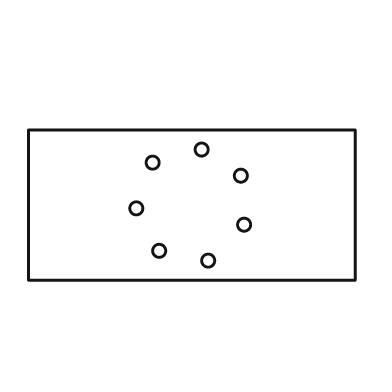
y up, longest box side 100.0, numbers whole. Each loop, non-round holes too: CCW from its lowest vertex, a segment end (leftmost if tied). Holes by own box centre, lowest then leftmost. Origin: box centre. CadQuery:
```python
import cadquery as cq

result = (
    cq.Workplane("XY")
    .moveTo(-50.0, -23.0)
    .lineTo(50.0, -23.0)
    .lineTo(50.0, 23.0)
    .lineTo(-50.0, 23.0)
    .close()
    .moveTo(5.0, -17.0)
    .circle(2.0)
    .moveTo(-10.0, -14.0)
    .circle(2.0)
    .moveTo(16.0, -6.0)
    .circle(2.0)
    .moveTo(-17.0, -1.0)
    .circle(2.0)
    .moveTo(15.0, 9.0)
    .circle(2.0)
    .moveTo(-12.0, 13.0)
    .circle(2.0)
    .moveTo(3.0, 17.0)
    .circle(2.0)
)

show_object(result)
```